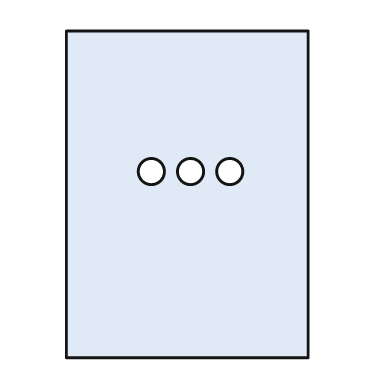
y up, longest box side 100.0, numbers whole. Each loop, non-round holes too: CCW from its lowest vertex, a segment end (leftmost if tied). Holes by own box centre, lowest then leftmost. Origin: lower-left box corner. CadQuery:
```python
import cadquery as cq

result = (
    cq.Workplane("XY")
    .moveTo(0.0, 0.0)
    .lineTo(74.0, 0.0)
    .lineTo(74.0, 100.0)
    .lineTo(0.0, 100.0)
    .close()
    .moveTo(26.0, 57.0)
    .circle(4.0)
    .moveTo(38.0, 57.0)
    .circle(4.0)
    .moveTo(50.0, 57.0)
    .circle(4.0)
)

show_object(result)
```